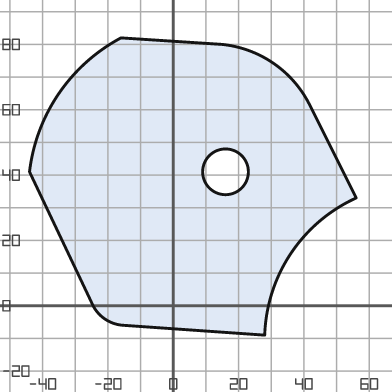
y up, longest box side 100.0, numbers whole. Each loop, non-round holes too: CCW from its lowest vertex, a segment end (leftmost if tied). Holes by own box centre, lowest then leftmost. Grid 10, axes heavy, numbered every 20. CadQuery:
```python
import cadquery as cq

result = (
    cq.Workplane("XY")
    .moveTo(28.0, -9.0)
    .threePointArc((36.0, 16.0), (56.0, 33.0))
    .lineTo(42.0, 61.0)
    .threePointArc((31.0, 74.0), (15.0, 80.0))
    .lineTo(-16.0, 82.0)
    .threePointArc((-35.0, 65.0), (-44.0, 41.0))
    .lineTo(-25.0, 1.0)
    .threePointArc((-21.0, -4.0), (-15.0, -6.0))
    .close()
    .moveTo(16.0, 41.0)
    .circle(7.0)
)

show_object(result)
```